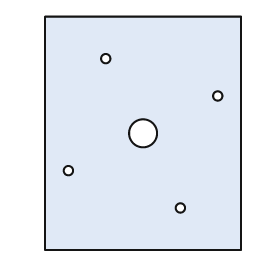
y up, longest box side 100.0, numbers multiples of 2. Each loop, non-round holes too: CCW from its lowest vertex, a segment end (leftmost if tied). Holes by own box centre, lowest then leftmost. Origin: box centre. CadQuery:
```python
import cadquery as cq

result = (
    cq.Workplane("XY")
    .moveTo(-42.0, -50.0)
    .lineTo(42.0, -50.0)
    .lineTo(42.0, 50.0)
    .lineTo(-42.0, 50.0)
    .close()
    .moveTo(16.0, -32.0)
    .circle(2.0)
    .moveTo(-32.0, -16.0)
    .circle(2.0)
    .moveTo(0.0, 0.0)
    .circle(6.0)
    .moveTo(32.0, 16.0)
    .circle(2.0)
    .moveTo(-16.0, 32.0)
    .circle(2.0)
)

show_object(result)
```